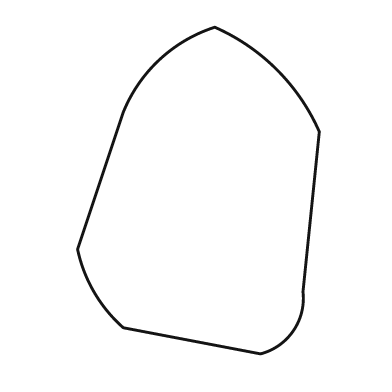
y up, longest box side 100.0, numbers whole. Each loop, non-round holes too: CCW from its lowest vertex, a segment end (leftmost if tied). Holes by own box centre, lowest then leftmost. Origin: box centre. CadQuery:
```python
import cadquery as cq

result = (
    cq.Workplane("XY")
    .moveTo(19.0, -50.0)
    .threePointArc((29.0, -43.0), (32.0, -31.0))
    .lineTo(37.0, 18.0)
    .threePointArc((24.0, 37.0), (5.0, 50.0))
    .threePointArc((-12.0, 40.0), (-23.0, 24.0))
    .lineTo(-37.0, -18.0)
    .threePointArc((-32.0, -31.0), (-23.0, -42.0))
    .close()
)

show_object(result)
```